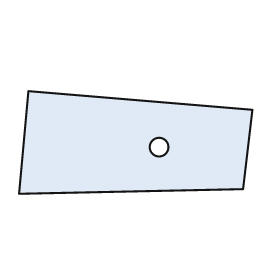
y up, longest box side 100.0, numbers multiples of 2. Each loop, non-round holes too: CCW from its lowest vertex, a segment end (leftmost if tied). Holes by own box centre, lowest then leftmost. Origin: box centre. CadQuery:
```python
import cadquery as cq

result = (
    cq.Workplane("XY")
    .moveTo(-50.0, -22.0)
    .lineTo(46.0, -20.0)
    .lineTo(50.0, 14.0)
    .lineTo(-46.0, 22.0)
    .close()
    .moveTo(10.0, -2.0)
    .circle(4.0)
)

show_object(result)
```